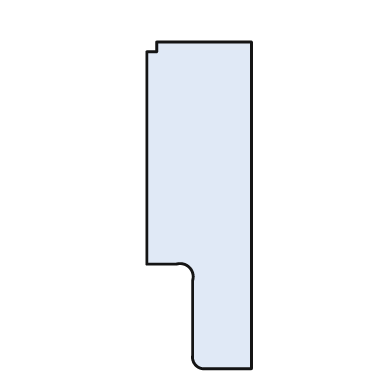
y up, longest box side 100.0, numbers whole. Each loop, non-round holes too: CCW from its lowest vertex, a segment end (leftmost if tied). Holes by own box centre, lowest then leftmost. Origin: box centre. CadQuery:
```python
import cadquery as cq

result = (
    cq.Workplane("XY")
    .moveTo(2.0, -50.0)
    .lineTo(16.0, -50.0)
    .lineTo(16.0, 50.0)
    .lineTo(-13.0, 50.0)
    .lineTo(-13.0, 47.0)
    .lineTo(-16.0, 47.0)
    .lineTo(-16.0, -18.0)
    .lineTo(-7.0, -18.0)
    .threePointArc((-3.0, -19.0), (-2.0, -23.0))
    .lineTo(-2.0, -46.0)
    .threePointArc((-1.0, -49.0), (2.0, -50.0))
    .close()
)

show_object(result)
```